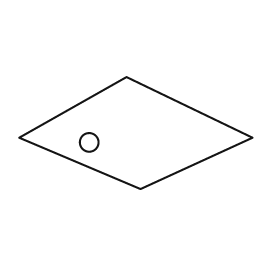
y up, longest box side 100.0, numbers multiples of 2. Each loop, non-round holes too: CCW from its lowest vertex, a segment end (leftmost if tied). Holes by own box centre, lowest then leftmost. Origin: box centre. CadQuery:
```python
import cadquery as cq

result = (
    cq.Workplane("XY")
    .moveTo(2.0, -24.0)
    .lineTo(50.0, -2.0)
    .lineTo(-4.0, 24.0)
    .lineTo(-50.0, -2.0)
    .close()
    .moveTo(-20.0, -4.0)
    .circle(4.0)
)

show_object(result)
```